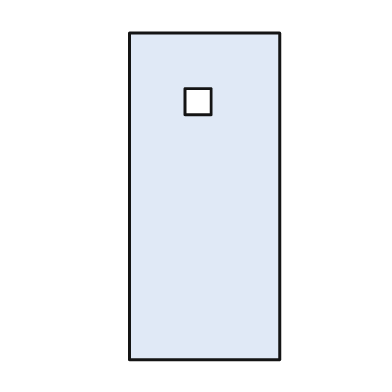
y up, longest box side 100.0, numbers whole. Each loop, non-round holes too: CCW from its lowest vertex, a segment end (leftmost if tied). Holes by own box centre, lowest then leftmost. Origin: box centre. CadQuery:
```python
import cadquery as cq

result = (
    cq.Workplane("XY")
    .moveTo(-23.0, -50.0)
    .lineTo(23.0, -50.0)
    .lineTo(23.0, 50.0)
    .lineTo(-23.0, 50.0)
    .close()
    .moveTo(-6.0, 25.0)
    .lineTo(2.0, 25.0)
    .lineTo(2.0, 33.0)
    .lineTo(-6.0, 33.0)
    .close()
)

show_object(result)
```